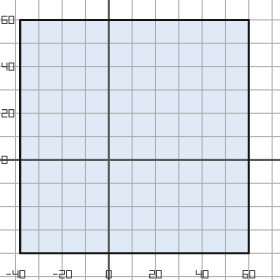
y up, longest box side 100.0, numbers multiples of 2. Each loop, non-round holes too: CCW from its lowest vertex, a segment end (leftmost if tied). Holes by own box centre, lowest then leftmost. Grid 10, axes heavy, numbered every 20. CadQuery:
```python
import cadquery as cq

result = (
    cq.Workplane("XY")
    .moveTo(-38.0, -40.0)
    .lineTo(60.0, -40.0)
    .lineTo(60.0, 60.0)
    .lineTo(-38.0, 60.0)
    .close()
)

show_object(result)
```